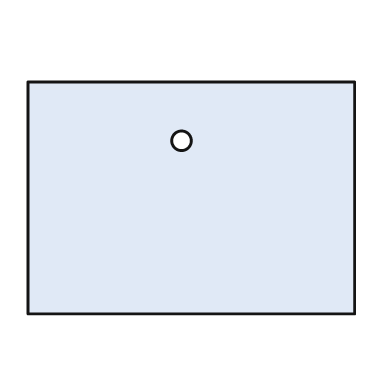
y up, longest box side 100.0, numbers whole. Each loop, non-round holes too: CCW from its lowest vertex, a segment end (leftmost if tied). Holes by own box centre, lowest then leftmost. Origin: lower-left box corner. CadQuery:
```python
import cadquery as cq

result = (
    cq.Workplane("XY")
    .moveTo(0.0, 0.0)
    .lineTo(100.0, 0.0)
    .lineTo(100.0, 71.0)
    .lineTo(0.0, 71.0)
    .close()
    .moveTo(47.0, 53.0)
    .circle(3.0)
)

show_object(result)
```